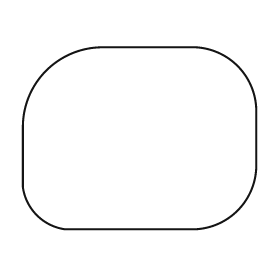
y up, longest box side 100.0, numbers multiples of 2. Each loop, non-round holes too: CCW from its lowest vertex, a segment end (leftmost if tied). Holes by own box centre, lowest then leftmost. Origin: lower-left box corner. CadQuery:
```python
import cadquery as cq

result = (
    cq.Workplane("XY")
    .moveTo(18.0, 0.0)
    .lineTo(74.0, 0.0)
    .threePointArc((92.0, 8.0), (100.0, 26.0))
    .lineTo(100.0, 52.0)
    .threePointArc((92.0, 70.0), (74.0, 78.0))
    .lineTo(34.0, 78.0)
    .threePointArc((10.0, 68.0), (0.0, 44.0))
    .lineTo(0.0, 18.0)
    .threePointArc((6.0, 6.0), (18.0, 0.0))
    .close()
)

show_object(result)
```